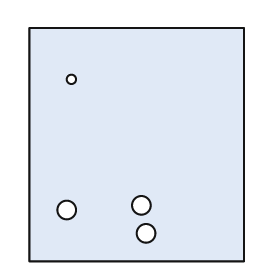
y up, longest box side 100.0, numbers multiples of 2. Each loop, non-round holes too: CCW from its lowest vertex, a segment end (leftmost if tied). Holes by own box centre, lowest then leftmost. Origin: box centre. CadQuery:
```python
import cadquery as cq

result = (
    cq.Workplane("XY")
    .moveTo(-46.0, -50.0)
    .lineTo(46.0, -50.0)
    .lineTo(46.0, 50.0)
    .lineTo(-46.0, 50.0)
    .close()
    .moveTo(4.0, -38.0)
    .circle(4.0)
    .moveTo(-30.0, -28.0)
    .circle(4.0)
    .moveTo(2.0, -26.0)
    .circle(4.0)
    .moveTo(-28.0, 28.0)
    .circle(2.0)
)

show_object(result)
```